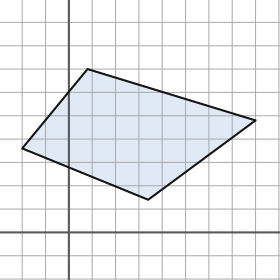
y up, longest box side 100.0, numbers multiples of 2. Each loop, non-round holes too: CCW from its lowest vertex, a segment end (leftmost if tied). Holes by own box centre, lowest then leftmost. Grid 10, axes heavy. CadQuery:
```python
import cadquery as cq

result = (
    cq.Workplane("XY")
    .moveTo(34.0, 14.0)
    .lineTo(80.0, 48.0)
    .lineTo(8.0, 70.0)
    .lineTo(-20.0, 36.0)
    .close()
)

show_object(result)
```